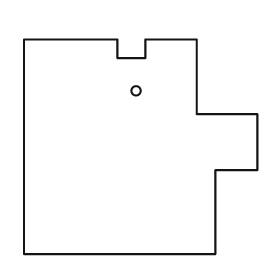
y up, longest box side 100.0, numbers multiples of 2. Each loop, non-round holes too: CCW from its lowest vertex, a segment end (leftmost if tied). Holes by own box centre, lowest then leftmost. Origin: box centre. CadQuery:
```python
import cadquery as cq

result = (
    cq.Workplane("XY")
    .moveTo(-50.0, -46.0)
    .lineTo(32.0, -46.0)
    .lineTo(32.0, -10.0)
    .lineTo(50.0, -10.0)
    .lineTo(50.0, 14.0)
    .lineTo(24.0, 14.0)
    .lineTo(24.0, 46.0)
    .lineTo(2.0, 46.0)
    .lineTo(2.0, 38.0)
    .lineTo(-10.0, 38.0)
    .lineTo(-10.0, 46.0)
    .lineTo(-50.0, 46.0)
    .close()
    .moveTo(-2.0, 24.0)
    .circle(2.0)
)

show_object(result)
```